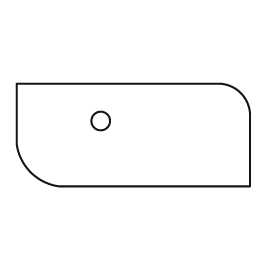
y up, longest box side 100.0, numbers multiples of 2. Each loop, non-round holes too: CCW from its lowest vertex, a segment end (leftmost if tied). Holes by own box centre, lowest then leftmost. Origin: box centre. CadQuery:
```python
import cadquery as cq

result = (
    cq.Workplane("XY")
    .moveTo(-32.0, -22.0)
    .lineTo(50.0, -22.0)
    .lineTo(50.0, 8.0)
    .threePointArc((46.0, 18.0), (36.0, 22.0))
    .lineTo(-50.0, 22.0)
    .lineTo(-50.0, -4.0)
    .threePointArc((-44.0, -16.0), (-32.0, -22.0))
    .close()
    .moveTo(-14.0, 6.0)
    .circle(4.0)
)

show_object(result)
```